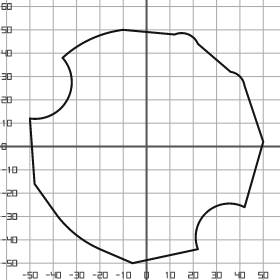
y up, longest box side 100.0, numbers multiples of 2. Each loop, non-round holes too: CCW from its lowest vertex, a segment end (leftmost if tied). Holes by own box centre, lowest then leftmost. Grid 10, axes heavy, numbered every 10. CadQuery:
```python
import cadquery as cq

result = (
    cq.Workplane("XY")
    .moveTo(-6.0, -50.0)
    .lineTo(22.0, -44.0)
    .threePointArc((26.0, -28.0), (42.0, -26.0))
    .lineTo(50.0, 2.0)
    .lineTo(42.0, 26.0)
    .threePointArc((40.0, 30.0), (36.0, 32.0))
    .lineTo(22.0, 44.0)
    .threePointArc((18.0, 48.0), (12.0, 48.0))
    .lineTo(-10.0, 50.0)
    .threePointArc((-24.0, 46.0), (-36.0, 38.0))
    .threePointArc((-34.0, 20.0), (-50.0, 12.0))
    .lineTo(-48.0, -16.0)
    .lineTo(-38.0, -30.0)
    .threePointArc((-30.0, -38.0), (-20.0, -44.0))
    .close()
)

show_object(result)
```